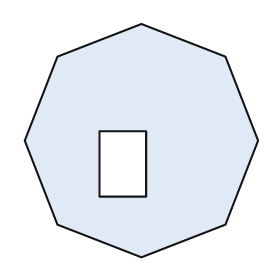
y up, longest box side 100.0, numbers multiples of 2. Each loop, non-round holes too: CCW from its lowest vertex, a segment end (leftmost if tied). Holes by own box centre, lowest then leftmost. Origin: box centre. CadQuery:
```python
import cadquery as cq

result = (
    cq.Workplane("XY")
    .moveTo(0.0, -50.0)
    .lineTo(36.0, -36.0)
    .lineTo(50.0, 0.0)
    .lineTo(36.0, 36.0)
    .lineTo(0.0, 50.0)
    .lineTo(-36.0, 36.0)
    .lineTo(-50.0, 0.0)
    .lineTo(-36.0, -36.0)
    .close()
    .moveTo(-18.0, -24.0)
    .lineTo(2.0, -24.0)
    .lineTo(2.0, 4.0)
    .lineTo(-18.0, 4.0)
    .close()
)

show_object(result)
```